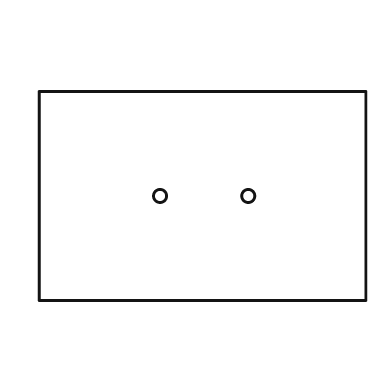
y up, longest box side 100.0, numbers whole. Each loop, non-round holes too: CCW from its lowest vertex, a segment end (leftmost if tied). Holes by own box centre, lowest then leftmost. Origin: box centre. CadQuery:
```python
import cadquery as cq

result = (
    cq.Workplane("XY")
    .moveTo(-50.0, -32.0)
    .lineTo(50.0, -32.0)
    .lineTo(50.0, 32.0)
    .lineTo(-50.0, 32.0)
    .close()
    .moveTo(-13.0, 0.0)
    .circle(2.0)
    .moveTo(14.0, 0.0)
    .circle(2.0)
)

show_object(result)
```